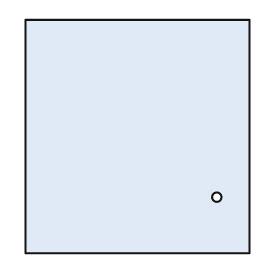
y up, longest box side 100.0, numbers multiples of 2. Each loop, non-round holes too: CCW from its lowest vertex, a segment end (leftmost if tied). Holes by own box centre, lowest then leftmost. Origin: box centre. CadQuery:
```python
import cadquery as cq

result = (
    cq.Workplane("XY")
    .moveTo(-48.0, -50.0)
    .lineTo(48.0, -50.0)
    .lineTo(48.0, 50.0)
    .lineTo(-48.0, 50.0)
    .close()
    .moveTo(34.0, -26.0)
    .circle(2.0)
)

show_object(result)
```